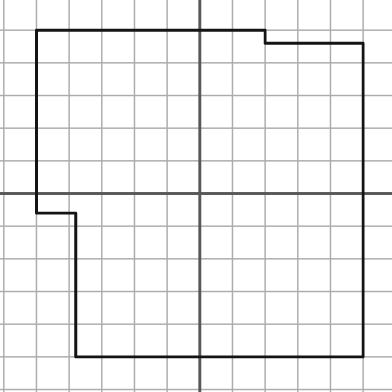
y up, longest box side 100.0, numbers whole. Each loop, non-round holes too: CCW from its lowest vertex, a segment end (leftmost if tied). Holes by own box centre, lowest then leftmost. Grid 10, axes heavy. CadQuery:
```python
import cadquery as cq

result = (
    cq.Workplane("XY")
    .moveTo(-38.0, -50.0)
    .lineTo(50.0, -50.0)
    .lineTo(50.0, 46.0)
    .lineTo(20.0, 46.0)
    .lineTo(20.0, 50.0)
    .lineTo(-50.0, 50.0)
    .lineTo(-50.0, -6.0)
    .lineTo(-38.0, -6.0)
    .close()
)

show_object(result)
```